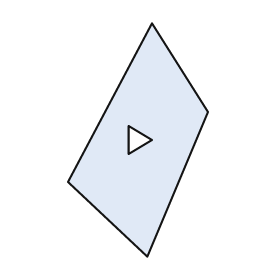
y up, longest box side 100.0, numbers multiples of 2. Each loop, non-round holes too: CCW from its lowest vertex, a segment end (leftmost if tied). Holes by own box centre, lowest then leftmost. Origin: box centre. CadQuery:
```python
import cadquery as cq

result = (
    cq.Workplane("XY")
    .moveTo(4.0, -50.0)
    .lineTo(30.0, 12.0)
    .lineTo(6.0, 50.0)
    .lineTo(-30.0, -18.0)
    .close()
    .moveTo(-4.0, -6.0)
    .lineTo(6.0, 0.0)
    .lineTo(-4.0, 6.0)
    .close()
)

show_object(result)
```